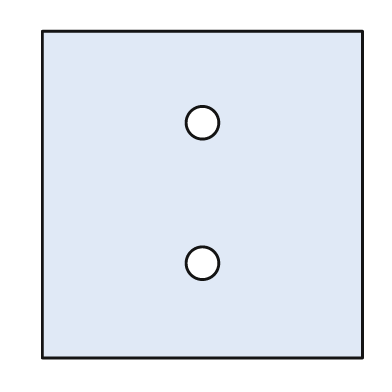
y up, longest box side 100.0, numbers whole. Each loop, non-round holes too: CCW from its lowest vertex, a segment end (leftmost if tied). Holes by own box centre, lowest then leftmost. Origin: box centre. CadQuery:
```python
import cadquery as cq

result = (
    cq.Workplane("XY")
    .moveTo(-49.0, -50.0)
    .lineTo(49.0, -50.0)
    .lineTo(49.0, 50.0)
    .lineTo(-49.0, 50.0)
    .close()
    .moveTo(0.0, -21.0)
    .circle(5.0)
    .moveTo(0.0, 22.0)
    .circle(5.0)
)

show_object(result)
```